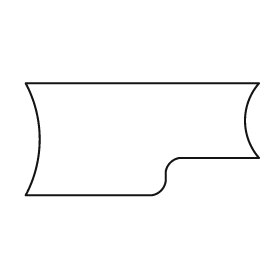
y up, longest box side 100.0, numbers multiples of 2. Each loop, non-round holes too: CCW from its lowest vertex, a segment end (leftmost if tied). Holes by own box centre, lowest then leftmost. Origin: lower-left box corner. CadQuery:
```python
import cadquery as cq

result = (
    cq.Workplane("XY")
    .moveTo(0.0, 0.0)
    .lineTo(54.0, 0.0)
    .threePointArc((58.0, 2.0), (60.0, 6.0))
    .lineTo(60.0, 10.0)
    .threePointArc((62.0, 14.0), (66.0, 16.0))
    .lineTo(100.0, 16.0)
    .threePointArc((94.0, 32.0), (100.0, 48.0))
    .lineTo(0.0, 48.0)
    .threePointArc((6.0, 24.0), (0.0, 0.0))
    .close()
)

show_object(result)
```